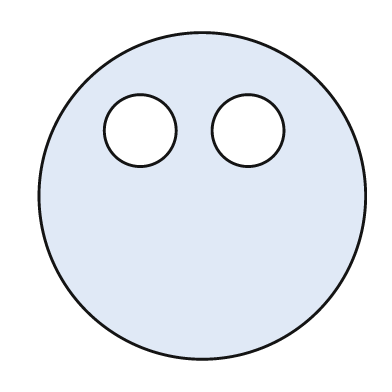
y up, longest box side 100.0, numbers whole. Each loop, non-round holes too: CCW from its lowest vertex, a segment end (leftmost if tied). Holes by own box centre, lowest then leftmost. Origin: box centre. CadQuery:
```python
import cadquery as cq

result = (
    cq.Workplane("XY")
    .moveTo(0.0, 0.0)
    .circle(50.0)
    .moveTo(-19.0, 20.0)
    .circle(11.0)
    .moveTo(14.0, 20.0)
    .circle(11.0)
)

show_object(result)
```